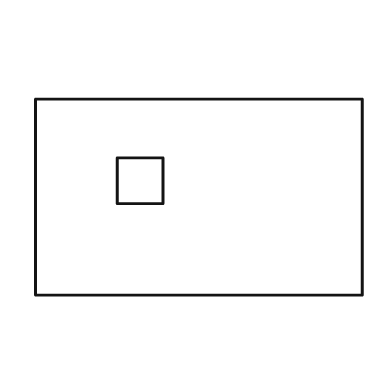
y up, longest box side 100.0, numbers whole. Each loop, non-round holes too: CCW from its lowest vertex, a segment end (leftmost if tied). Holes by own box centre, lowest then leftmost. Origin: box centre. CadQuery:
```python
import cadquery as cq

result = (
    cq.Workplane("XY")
    .moveTo(-50.0, -30.0)
    .lineTo(50.0, -30.0)
    .lineTo(50.0, 30.0)
    .lineTo(-50.0, 30.0)
    .close()
    .moveTo(-25.0, -2.0)
    .lineTo(-11.0, -2.0)
    .lineTo(-11.0, 12.0)
    .lineTo(-25.0, 12.0)
    .close()
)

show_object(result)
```